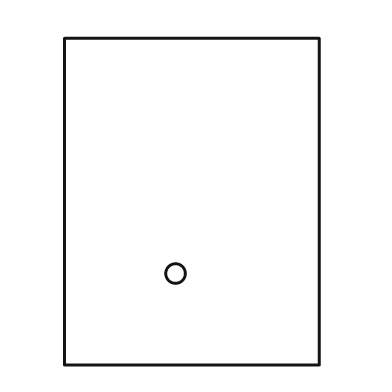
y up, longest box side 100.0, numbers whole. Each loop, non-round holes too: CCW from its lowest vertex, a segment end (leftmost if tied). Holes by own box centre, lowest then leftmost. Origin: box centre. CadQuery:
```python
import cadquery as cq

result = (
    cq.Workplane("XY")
    .moveTo(-39.0, -50.0)
    .lineTo(39.0, -50.0)
    .lineTo(39.0, 50.0)
    .lineTo(-39.0, 50.0)
    .close()
    .moveTo(-5.0, -22.0)
    .circle(3.0)
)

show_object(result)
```